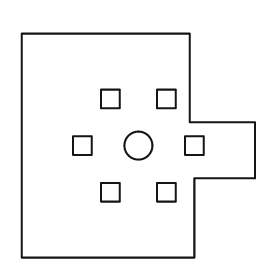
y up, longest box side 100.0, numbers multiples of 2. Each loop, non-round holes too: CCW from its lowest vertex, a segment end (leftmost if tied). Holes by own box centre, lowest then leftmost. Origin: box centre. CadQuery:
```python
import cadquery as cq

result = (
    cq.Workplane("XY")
    .moveTo(-50.0, -48.0)
    .lineTo(24.0, -48.0)
    .lineTo(24.0, -14.0)
    .lineTo(50.0, -14.0)
    .lineTo(50.0, 10.0)
    .lineTo(22.0, 10.0)
    .lineTo(22.0, 48.0)
    .lineTo(-50.0, 48.0)
    .close()
    .moveTo(-16.0, -24.0)
    .lineTo(-8.0, -24.0)
    .lineTo(-8.0, -16.0)
    .lineTo(-16.0, -16.0)
    .close()
    .moveTo(8.0, -24.0)
    .lineTo(16.0, -24.0)
    .lineTo(16.0, -16.0)
    .lineTo(8.0, -16.0)
    .close()
    .moveTo(-28.0, -4.0)
    .lineTo(-20.0, -4.0)
    .lineTo(-20.0, 4.0)
    .lineTo(-28.0, 4.0)
    .close()
    .moveTo(0.0, 0.0)
    .circle(6.0)
    .moveTo(20.0, -4.0)
    .lineTo(28.0, -4.0)
    .lineTo(28.0, 4.0)
    .lineTo(20.0, 4.0)
    .close()
    .moveTo(-16.0, 16.0)
    .lineTo(-8.0, 16.0)
    .lineTo(-8.0, 24.0)
    .lineTo(-16.0, 24.0)
    .close()
    .moveTo(8.0, 16.0)
    .lineTo(16.0, 16.0)
    .lineTo(16.0, 24.0)
    .lineTo(8.0, 24.0)
    .close()
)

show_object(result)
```